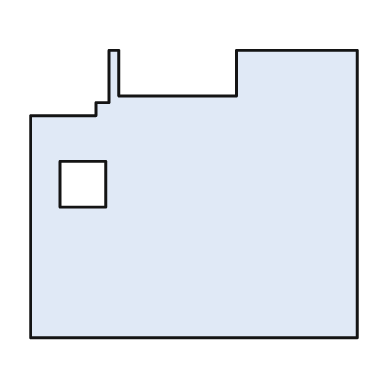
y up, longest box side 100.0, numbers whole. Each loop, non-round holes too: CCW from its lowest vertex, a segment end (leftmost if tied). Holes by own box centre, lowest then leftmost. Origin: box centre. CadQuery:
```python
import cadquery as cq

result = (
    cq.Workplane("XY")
    .moveTo(-50.0, -44.0)
    .lineTo(50.0, -44.0)
    .lineTo(50.0, 44.0)
    .lineTo(13.0, 44.0)
    .lineTo(13.0, 30.0)
    .lineTo(-23.0, 30.0)
    .lineTo(-23.0, 44.0)
    .lineTo(-26.0, 44.0)
    .lineTo(-26.0, 28.0)
    .lineTo(-30.0, 28.0)
    .lineTo(-30.0, 24.0)
    .lineTo(-50.0, 24.0)
    .close()
    .moveTo(-41.0, -4.0)
    .lineTo(-27.0, -4.0)
    .lineTo(-27.0, 10.0)
    .lineTo(-41.0, 10.0)
    .close()
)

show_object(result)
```